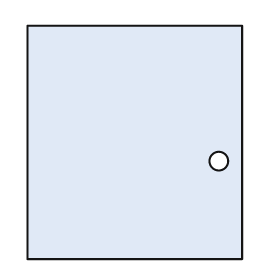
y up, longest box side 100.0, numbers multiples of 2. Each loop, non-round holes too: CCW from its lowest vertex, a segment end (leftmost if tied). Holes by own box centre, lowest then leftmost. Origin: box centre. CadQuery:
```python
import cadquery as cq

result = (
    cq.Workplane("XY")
    .moveTo(-46.0, -50.0)
    .lineTo(46.0, -50.0)
    .lineTo(46.0, 50.0)
    .lineTo(-46.0, 50.0)
    .close()
    .moveTo(36.0, -8.0)
    .circle(4.0)
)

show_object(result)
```